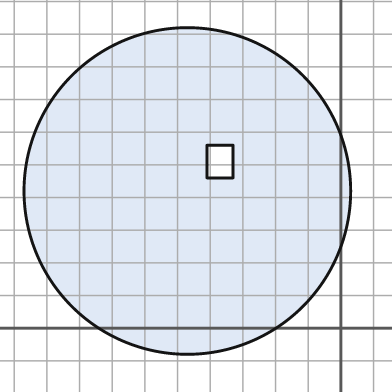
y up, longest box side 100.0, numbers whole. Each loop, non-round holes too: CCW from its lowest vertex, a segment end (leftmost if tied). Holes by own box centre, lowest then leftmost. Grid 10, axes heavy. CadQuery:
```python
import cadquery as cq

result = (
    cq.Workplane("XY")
    .moveTo(-47.0, 42.0)
    .circle(50.0)
    .moveTo(-41.0, 46.0)
    .lineTo(-33.0, 46.0)
    .lineTo(-33.0, 56.0)
    .lineTo(-41.0, 56.0)
    .close()
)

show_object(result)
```